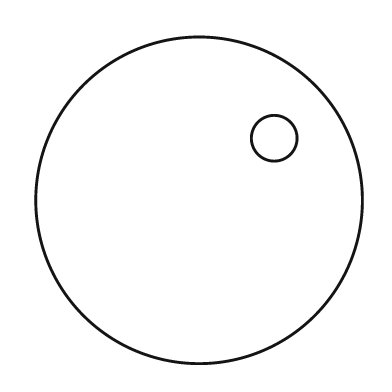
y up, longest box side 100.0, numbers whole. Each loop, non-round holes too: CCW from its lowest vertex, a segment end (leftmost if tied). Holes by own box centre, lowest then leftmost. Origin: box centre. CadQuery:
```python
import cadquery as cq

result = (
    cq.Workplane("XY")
    .moveTo(0.0, 0.0)
    .circle(50.0)
    .moveTo(23.0, 19.0)
    .circle(7.0)
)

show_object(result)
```